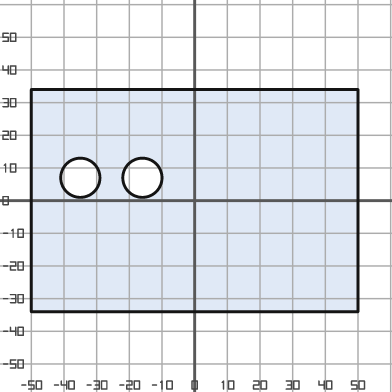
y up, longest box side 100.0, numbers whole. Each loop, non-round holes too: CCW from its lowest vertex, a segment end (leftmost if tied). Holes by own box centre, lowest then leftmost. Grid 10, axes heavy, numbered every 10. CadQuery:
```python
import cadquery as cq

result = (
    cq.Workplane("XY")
    .moveTo(-50.0, -34.0)
    .lineTo(50.0, -34.0)
    .lineTo(50.0, 34.0)
    .lineTo(-50.0, 34.0)
    .close()
    .moveTo(-35.0, 7.0)
    .circle(6.0)
    .moveTo(-16.0, 7.0)
    .circle(6.0)
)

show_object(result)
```